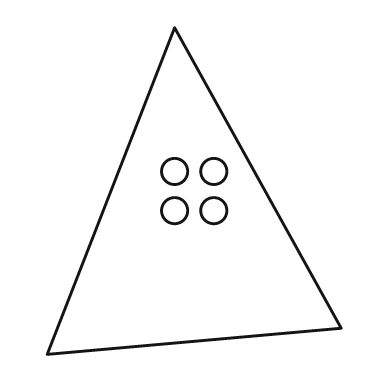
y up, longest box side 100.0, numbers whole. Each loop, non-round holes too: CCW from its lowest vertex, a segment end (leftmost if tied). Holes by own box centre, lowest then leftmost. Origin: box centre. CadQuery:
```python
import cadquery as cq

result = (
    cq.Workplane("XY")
    .moveTo(-45.0, -50.0)
    .lineTo(45.0, -42.0)
    .lineTo(-6.0, 50.0)
    .close()
    .moveTo(-6.0, -6.0)
    .circle(4.0)
    .moveTo(6.0, -6.0)
    .circle(4.0)
    .moveTo(-6.0, 6.0)
    .circle(4.0)
    .moveTo(6.0, 6.0)
    .circle(4.0)
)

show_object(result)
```